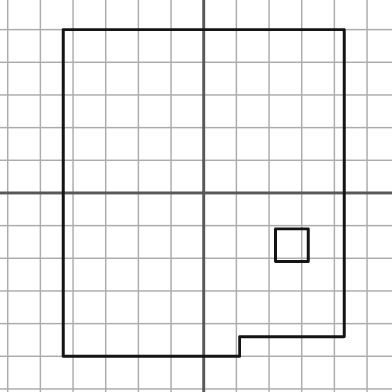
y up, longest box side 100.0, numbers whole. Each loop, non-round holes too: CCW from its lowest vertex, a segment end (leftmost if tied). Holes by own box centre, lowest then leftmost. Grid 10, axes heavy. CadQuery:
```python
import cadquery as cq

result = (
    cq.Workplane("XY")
    .moveTo(-43.0, -50.0)
    .lineTo(11.0, -50.0)
    .lineTo(11.0, -44.0)
    .lineTo(43.0, -44.0)
    .lineTo(43.0, 50.0)
    .lineTo(-43.0, 50.0)
    .close()
    .moveTo(22.0, -21.0)
    .lineTo(32.0, -21.0)
    .lineTo(32.0, -11.0)
    .lineTo(22.0, -11.0)
    .close()
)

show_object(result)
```